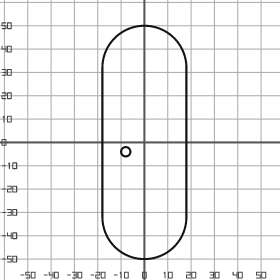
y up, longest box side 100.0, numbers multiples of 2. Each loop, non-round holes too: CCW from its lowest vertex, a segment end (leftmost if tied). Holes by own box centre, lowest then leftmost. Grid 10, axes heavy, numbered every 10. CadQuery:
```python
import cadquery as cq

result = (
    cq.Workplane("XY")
    .moveTo(-18.0, -32.0)
    .threePointArc((0.0, -50.0), (18.0, -32.0))
    .lineTo(18.0, 32.0)
    .threePointArc((0.0, 50.0), (-18.0, 32.0))
    .close()
    .moveTo(-8.0, -4.0)
    .circle(2.0)
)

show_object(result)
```